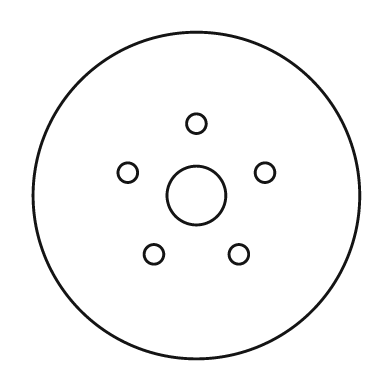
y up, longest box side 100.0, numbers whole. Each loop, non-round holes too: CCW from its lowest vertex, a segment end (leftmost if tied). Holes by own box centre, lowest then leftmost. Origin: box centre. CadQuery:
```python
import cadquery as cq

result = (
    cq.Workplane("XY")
    .moveTo(0.0, 0.0)
    .circle(50.0)
    .moveTo(-13.0, -18.0)
    .circle(3.0)
    .moveTo(13.0, -18.0)
    .circle(3.0)
    .moveTo(0.0, 0.0)
    .circle(9.0)
    .moveTo(-21.0, 7.0)
    .circle(3.0)
    .moveTo(21.0, 7.0)
    .circle(3.0)
    .moveTo(0.0, 22.0)
    .circle(3.0)
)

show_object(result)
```